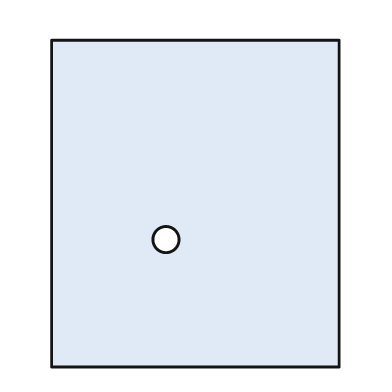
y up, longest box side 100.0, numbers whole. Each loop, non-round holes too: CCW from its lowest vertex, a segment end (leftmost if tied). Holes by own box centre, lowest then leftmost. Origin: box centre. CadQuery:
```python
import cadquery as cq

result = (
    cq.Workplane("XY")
    .moveTo(-44.0, -50.0)
    .lineTo(44.0, -50.0)
    .lineTo(44.0, 50.0)
    .lineTo(-44.0, 50.0)
    .close()
    .moveTo(-9.0, -11.0)
    .circle(4.0)
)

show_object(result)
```